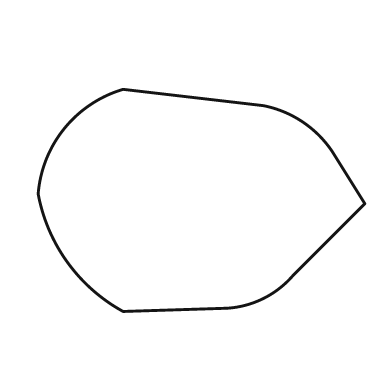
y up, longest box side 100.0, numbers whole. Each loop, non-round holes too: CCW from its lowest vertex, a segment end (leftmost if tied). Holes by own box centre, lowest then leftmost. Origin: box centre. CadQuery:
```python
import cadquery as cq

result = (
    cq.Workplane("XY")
    .moveTo(-24.0, -34.0)
    .lineTo(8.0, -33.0)
    .threePointArc((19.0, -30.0), (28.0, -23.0))
    .lineTo(50.0, -1.0)
    .lineTo(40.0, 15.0)
    .threePointArc((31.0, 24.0), (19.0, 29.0))
    .lineTo(-24.0, 34.0)
    .threePointArc((-42.0, 22.0), (-50.0, 2.0))
    .threePointArc((-41.0, -19.0), (-24.0, -34.0))
    .close()
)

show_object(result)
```